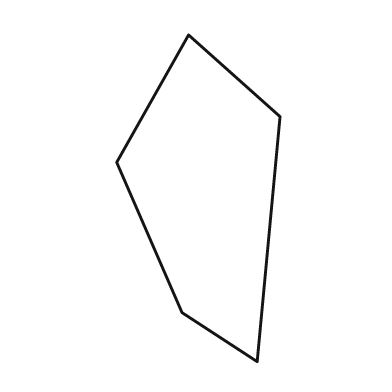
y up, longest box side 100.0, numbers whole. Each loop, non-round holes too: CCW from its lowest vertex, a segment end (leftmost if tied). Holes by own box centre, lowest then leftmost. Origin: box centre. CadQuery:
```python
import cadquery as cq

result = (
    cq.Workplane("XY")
    .moveTo(18.0, -50.0)
    .lineTo(25.0, 25.0)
    .lineTo(-3.0, 50.0)
    .lineTo(-25.0, 11.0)
    .lineTo(-5.0, -35.0)
    .close()
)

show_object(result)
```